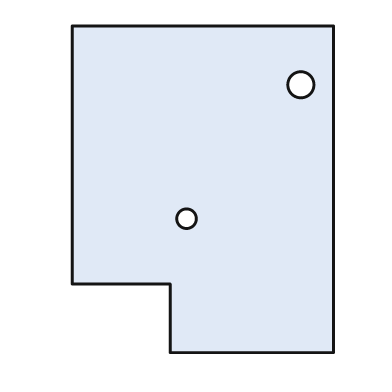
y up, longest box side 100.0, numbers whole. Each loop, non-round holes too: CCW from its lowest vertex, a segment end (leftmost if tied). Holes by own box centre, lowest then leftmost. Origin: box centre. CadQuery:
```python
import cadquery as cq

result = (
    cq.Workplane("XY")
    .moveTo(-10.0, -50.0)
    .lineTo(40.0, -50.0)
    .lineTo(40.0, 50.0)
    .lineTo(-40.0, 50.0)
    .lineTo(-40.0, -29.0)
    .lineTo(-10.0, -29.0)
    .close()
    .moveTo(-5.0, -9.0)
    .circle(3.0)
    .moveTo(30.0, 32.0)
    .circle(4.0)
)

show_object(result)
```